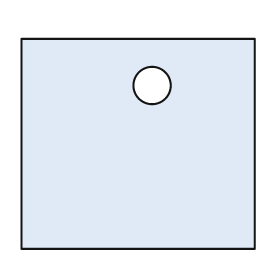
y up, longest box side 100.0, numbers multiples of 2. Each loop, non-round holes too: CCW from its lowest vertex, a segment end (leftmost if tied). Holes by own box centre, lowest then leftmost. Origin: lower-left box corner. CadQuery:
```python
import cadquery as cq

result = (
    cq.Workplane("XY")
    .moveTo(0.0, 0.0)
    .lineTo(100.0, 0.0)
    .lineTo(100.0, 90.0)
    .lineTo(0.0, 90.0)
    .close()
    .moveTo(56.0, 70.0)
    .circle(8.0)
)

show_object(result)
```